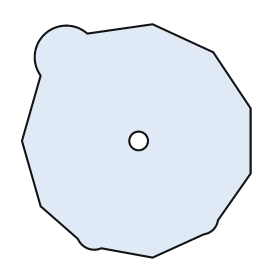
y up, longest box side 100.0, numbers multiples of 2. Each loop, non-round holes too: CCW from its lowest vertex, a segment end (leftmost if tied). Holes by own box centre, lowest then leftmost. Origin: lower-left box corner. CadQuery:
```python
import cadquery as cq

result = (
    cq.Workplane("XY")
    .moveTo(56.0, 0.0)
    .lineTo(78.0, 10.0)
    .threePointArc((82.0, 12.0), (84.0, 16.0))
    .lineTo(98.0, 36.0)
    .lineTo(98.0, 64.0)
    .lineTo(82.0, 88.0)
    .lineTo(56.0, 100.0)
    .lineTo(28.0, 96.0)
    .threePointArc((10.0, 96.0), (8.0, 78.0))
    .lineTo(0.0, 50.0)
    .lineTo(8.0, 22.0)
    .lineTo(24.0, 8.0)
    .threePointArc((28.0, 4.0), (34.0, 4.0))
    .close()
    .moveTo(50.0, 50.0)
    .circle(4.0)
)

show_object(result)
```